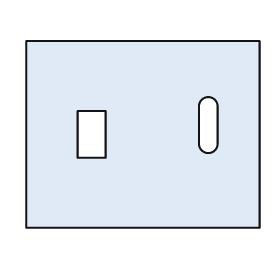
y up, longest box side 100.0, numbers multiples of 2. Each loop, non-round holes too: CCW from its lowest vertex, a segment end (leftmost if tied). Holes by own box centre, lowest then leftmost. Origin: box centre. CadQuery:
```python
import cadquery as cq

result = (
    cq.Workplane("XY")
    .moveTo(-50.0, -40.0)
    .lineTo(50.0, -40.0)
    .lineTo(50.0, 40.0)
    .lineTo(-50.0, 40.0)
    .close()
    .moveTo(-28.0, -10.0)
    .lineTo(-16.0, -10.0)
    .lineTo(-16.0, 10.0)
    .lineTo(-28.0, 10.0)
    .close()
    .moveTo(24.0, -4.0)
    .threePointArc((28.0, -8.0), (32.0, -4.0))
    .lineTo(32.0, 12.0)
    .threePointArc((28.0, 16.0), (24.0, 12.0))
    .close()
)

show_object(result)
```